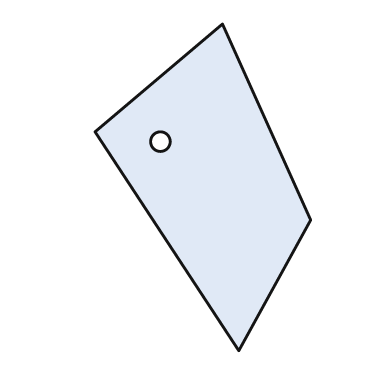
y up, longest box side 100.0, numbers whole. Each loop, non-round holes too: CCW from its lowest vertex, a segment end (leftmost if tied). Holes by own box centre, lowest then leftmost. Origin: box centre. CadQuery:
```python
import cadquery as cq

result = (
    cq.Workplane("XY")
    .moveTo(11.0, -50.0)
    .lineTo(33.0, -10.0)
    .lineTo(6.0, 50.0)
    .lineTo(-33.0, 17.0)
    .close()
    .moveTo(-13.0, 14.0)
    .circle(3.0)
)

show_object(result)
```